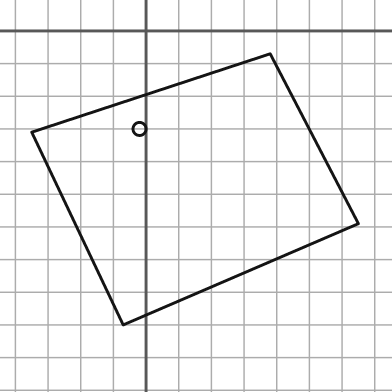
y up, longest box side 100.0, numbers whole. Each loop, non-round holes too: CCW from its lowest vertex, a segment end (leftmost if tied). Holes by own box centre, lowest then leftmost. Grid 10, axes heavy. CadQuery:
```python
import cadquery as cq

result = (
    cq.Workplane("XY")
    .moveTo(-7.0, -90.0)
    .lineTo(65.0, -59.0)
    .lineTo(38.0, -7.0)
    .lineTo(-35.0, -31.0)
    .close()
    .moveTo(-2.0, -30.0)
    .circle(2.0)
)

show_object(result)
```